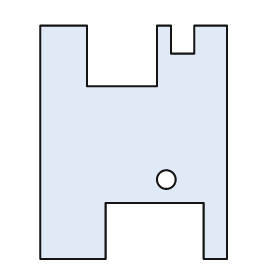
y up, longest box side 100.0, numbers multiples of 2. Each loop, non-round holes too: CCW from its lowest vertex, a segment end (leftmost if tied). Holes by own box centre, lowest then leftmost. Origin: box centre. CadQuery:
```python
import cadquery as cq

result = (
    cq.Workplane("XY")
    .moveTo(-40.0, -50.0)
    .lineTo(-12.0, -50.0)
    .lineTo(-12.0, -26.0)
    .lineTo(30.0, -26.0)
    .lineTo(30.0, -50.0)
    .lineTo(40.0, -50.0)
    .lineTo(40.0, 50.0)
    .lineTo(26.0, 50.0)
    .lineTo(26.0, 38.0)
    .lineTo(16.0, 38.0)
    .lineTo(16.0, 50.0)
    .lineTo(10.0, 50.0)
    .lineTo(10.0, 24.0)
    .lineTo(-20.0, 24.0)
    .lineTo(-20.0, 50.0)
    .lineTo(-40.0, 50.0)
    .close()
    .moveTo(14.0, -16.0)
    .circle(4.0)
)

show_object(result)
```